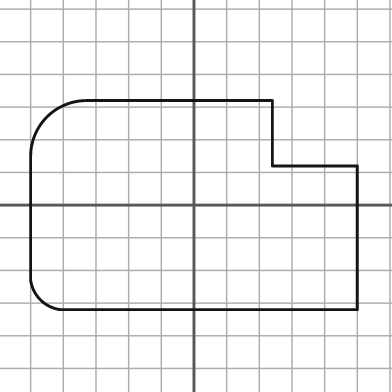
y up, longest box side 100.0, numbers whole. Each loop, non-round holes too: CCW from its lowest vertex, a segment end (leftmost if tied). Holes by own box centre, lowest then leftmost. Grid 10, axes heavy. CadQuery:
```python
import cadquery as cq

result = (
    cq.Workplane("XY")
    .moveTo(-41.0, -32.0)
    .lineTo(50.0, -32.0)
    .lineTo(50.0, 12.0)
    .lineTo(24.0, 12.0)
    .lineTo(24.0, 32.0)
    .lineTo(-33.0, 32.0)
    .threePointArc((-45.0, 27.0), (-50.0, 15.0))
    .lineTo(-50.0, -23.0)
    .threePointArc((-47.0, -29.0), (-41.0, -32.0))
    .close()
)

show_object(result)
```